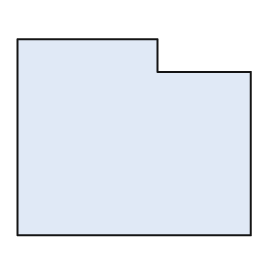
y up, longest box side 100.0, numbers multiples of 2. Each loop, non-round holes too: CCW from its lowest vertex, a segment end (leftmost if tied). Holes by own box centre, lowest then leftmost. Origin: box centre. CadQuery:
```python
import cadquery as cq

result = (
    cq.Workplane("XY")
    .moveTo(-50.0, -42.0)
    .lineTo(50.0, -42.0)
    .lineTo(50.0, 28.0)
    .lineTo(10.0, 28.0)
    .lineTo(10.0, 42.0)
    .lineTo(-50.0, 42.0)
    .close()
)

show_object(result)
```